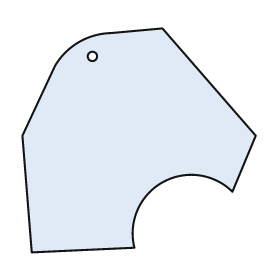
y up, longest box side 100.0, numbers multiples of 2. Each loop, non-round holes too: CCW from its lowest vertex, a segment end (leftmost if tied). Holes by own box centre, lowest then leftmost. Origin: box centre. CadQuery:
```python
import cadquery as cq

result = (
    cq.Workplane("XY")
    .moveTo(-46.0, -48.0)
    .lineTo(-2.0, -46.0)
    .threePointArc((10.0, -18.0), (40.0, -22.0))
    .lineTo(50.0, 2.0)
    .lineTo(10.0, 48.0)
    .lineTo(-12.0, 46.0)
    .threePointArc((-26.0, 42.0), (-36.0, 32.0))
    .lineTo(-50.0, 2.0)
    .close()
    .moveTo(-20.0, 36.0)
    .circle(2.0)
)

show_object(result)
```